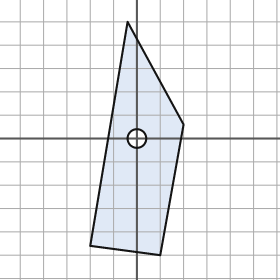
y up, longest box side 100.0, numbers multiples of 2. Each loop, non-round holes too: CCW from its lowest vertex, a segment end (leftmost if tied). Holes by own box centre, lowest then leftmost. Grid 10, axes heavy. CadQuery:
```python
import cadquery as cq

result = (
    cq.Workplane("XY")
    .moveTo(10.0, -50.0)
    .lineTo(20.0, 6.0)
    .lineTo(-4.0, 50.0)
    .lineTo(-20.0, -46.0)
    .close()
    .moveTo(0.0, 0.0)
    .circle(4.0)
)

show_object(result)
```